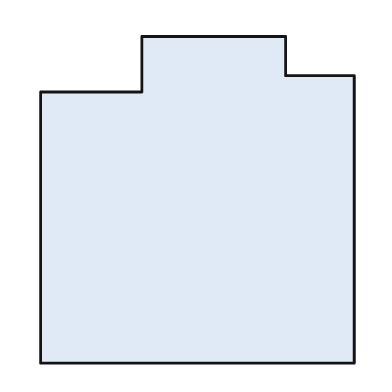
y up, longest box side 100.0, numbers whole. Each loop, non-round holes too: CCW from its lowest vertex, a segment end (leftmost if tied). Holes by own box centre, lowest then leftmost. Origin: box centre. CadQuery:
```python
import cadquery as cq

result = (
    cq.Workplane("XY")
    .moveTo(-48.0, -50.0)
    .lineTo(48.0, -50.0)
    .lineTo(48.0, 38.0)
    .lineTo(27.0, 38.0)
    .lineTo(27.0, 50.0)
    .lineTo(-17.0, 50.0)
    .lineTo(-17.0, 33.0)
    .lineTo(-48.0, 33.0)
    .close()
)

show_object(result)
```